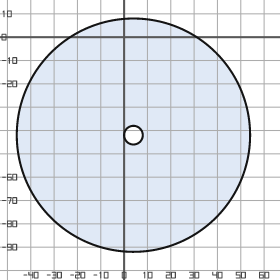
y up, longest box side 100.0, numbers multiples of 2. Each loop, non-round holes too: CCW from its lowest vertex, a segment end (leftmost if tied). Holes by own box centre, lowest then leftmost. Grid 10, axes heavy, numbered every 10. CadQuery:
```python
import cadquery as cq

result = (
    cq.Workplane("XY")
    .moveTo(4.0, -42.0)
    .circle(50.0)
    .moveTo(4.0, -42.0)
    .circle(4.0)
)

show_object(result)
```